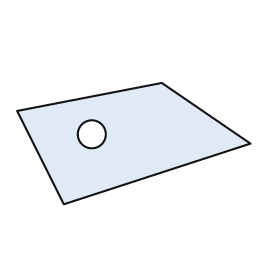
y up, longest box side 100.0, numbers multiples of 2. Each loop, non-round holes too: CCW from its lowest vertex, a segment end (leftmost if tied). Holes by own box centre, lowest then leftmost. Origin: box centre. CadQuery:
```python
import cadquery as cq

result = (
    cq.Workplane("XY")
    .moveTo(-30.0, -26.0)
    .lineTo(50.0, 0.0)
    .lineTo(12.0, 26.0)
    .lineTo(-50.0, 14.0)
    .close()
    .moveTo(-18.0, 4.0)
    .circle(6.0)
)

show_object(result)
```